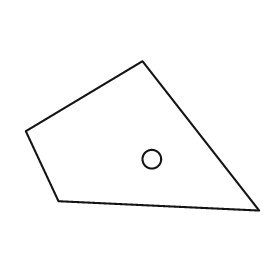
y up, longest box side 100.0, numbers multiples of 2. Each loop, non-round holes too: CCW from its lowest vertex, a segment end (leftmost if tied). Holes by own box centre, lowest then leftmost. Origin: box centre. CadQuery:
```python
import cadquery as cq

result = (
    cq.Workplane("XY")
    .moveTo(50.0, -32.0)
    .lineTo(0.0, 32.0)
    .lineTo(-50.0, 2.0)
    .lineTo(-36.0, -28.0)
    .close()
    .moveTo(4.0, -10.0)
    .circle(4.0)
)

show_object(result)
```